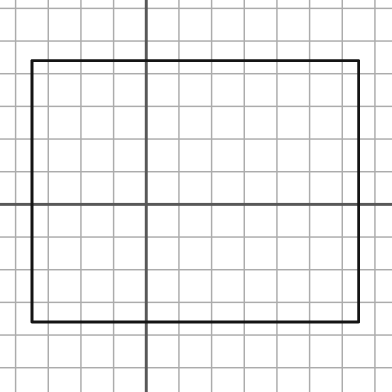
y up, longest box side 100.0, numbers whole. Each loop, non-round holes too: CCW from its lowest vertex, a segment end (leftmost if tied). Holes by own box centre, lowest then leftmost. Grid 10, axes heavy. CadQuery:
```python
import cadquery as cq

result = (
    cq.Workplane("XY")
    .moveTo(-35.0, -36.0)
    .lineTo(65.0, -36.0)
    .lineTo(65.0, 44.0)
    .lineTo(-35.0, 44.0)
    .close()
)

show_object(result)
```